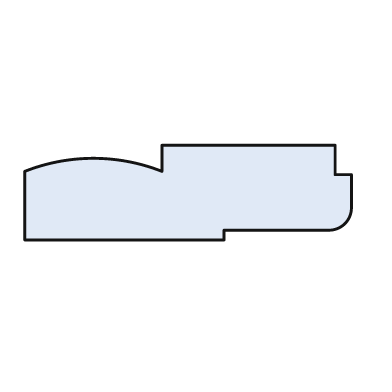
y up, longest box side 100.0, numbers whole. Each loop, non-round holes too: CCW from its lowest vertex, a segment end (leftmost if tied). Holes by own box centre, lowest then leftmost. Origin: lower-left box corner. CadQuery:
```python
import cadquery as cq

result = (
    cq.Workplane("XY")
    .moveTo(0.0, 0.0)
    .lineTo(61.0, 0.0)
    .lineTo(61.0, 3.0)
    .lineTo(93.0, 3.0)
    .threePointArc((98.0, 5.0), (100.0, 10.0))
    .lineTo(100.0, 20.0)
    .lineTo(95.0, 20.0)
    .lineTo(95.0, 29.0)
    .lineTo(42.0, 29.0)
    .lineTo(42.0, 21.0)
    .threePointArc((21.0, 25.0), (0.0, 21.0))
    .close()
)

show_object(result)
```